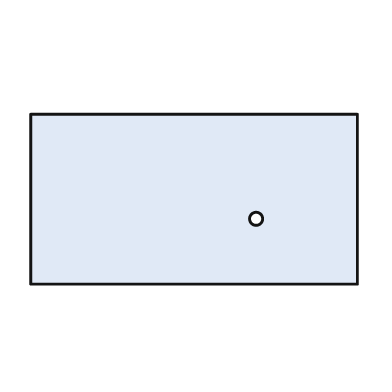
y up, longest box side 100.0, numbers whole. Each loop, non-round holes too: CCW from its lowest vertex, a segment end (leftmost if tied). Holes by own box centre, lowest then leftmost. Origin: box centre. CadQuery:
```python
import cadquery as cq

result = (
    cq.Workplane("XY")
    .moveTo(-50.0, -26.0)
    .lineTo(50.0, -26.0)
    .lineTo(50.0, 26.0)
    .lineTo(-50.0, 26.0)
    .close()
    .moveTo(19.0, -6.0)
    .circle(2.0)
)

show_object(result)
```